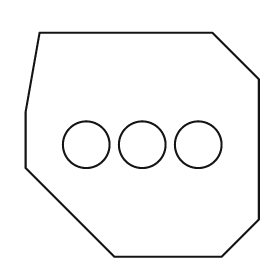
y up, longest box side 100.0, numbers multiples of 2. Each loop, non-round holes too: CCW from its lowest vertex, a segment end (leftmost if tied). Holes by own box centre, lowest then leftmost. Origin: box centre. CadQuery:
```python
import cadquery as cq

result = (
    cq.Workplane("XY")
    .moveTo(-12.0, -48.0)
    .lineTo(34.0, -48.0)
    .lineTo(50.0, -32.0)
    .lineTo(50.0, 28.0)
    .lineTo(30.0, 48.0)
    .lineTo(-44.0, 48.0)
    .lineTo(-50.0, 14.0)
    .lineTo(-50.0, -10.0)
    .close()
    .moveTo(-24.0, 0.0)
    .circle(10.0)
    .moveTo(0.0, 0.0)
    .circle(10.0)
    .moveTo(24.0, 0.0)
    .circle(10.0)
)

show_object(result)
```